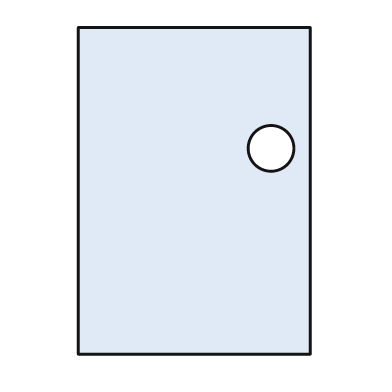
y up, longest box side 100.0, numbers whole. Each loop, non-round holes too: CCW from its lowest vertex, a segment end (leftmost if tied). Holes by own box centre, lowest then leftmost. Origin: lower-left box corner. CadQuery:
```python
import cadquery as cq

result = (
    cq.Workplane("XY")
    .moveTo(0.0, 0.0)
    .lineTo(71.0, 0.0)
    .lineTo(71.0, 100.0)
    .lineTo(0.0, 100.0)
    .close()
    .moveTo(59.0, 63.0)
    .circle(7.0)
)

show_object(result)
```